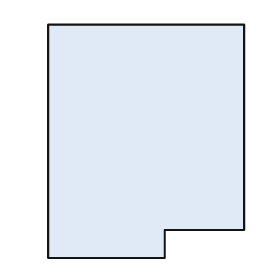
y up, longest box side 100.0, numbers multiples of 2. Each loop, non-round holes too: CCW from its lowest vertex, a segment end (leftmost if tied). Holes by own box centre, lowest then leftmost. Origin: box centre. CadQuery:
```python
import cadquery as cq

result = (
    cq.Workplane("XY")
    .moveTo(-42.0, -50.0)
    .lineTo(8.0, -50.0)
    .lineTo(8.0, -38.0)
    .lineTo(42.0, -38.0)
    .lineTo(42.0, 50.0)
    .lineTo(-42.0, 50.0)
    .close()
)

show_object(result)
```